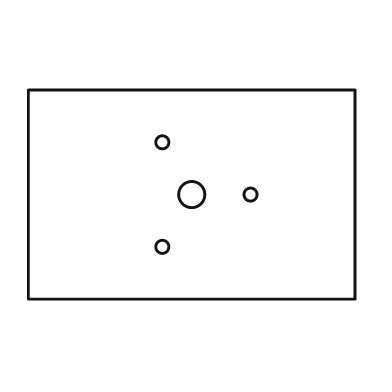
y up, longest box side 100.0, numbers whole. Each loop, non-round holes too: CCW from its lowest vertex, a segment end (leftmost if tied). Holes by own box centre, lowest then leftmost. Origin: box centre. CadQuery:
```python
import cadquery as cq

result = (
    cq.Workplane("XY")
    .moveTo(-50.0, -32.0)
    .lineTo(50.0, -32.0)
    .lineTo(50.0, 32.0)
    .lineTo(-50.0, 32.0)
    .close()
    .moveTo(-9.0, -16.0)
    .circle(2.0)
    .moveTo(0.0, 0.0)
    .circle(4.0)
    .moveTo(18.0, 0.0)
    .circle(2.0)
    .moveTo(-9.0, 16.0)
    .circle(2.0)
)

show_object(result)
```